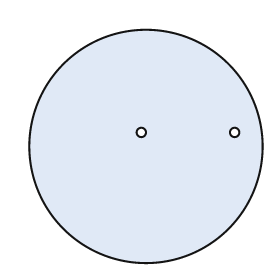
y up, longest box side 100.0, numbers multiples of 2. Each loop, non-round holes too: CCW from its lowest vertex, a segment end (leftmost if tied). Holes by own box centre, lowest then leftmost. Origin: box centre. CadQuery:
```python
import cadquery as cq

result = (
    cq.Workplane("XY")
    .moveTo(0.0, 0.0)
    .circle(50.0)
    .moveTo(-2.0, 6.0)
    .circle(2.0)
    .moveTo(38.0, 6.0)
    .circle(2.0)
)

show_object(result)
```